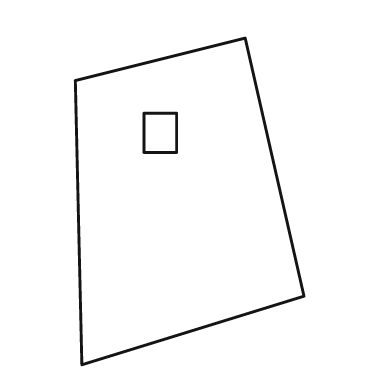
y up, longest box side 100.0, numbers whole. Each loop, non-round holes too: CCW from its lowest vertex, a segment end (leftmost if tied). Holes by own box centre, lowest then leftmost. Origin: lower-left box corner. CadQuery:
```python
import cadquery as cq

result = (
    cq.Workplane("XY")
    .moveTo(2.0, 0.0)
    .lineTo(70.0, 21.0)
    .lineTo(52.0, 100.0)
    .lineTo(0.0, 87.0)
    .close()
    .moveTo(21.0, 65.0)
    .lineTo(31.0, 65.0)
    .lineTo(31.0, 77.0)
    .lineTo(21.0, 77.0)
    .close()
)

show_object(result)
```